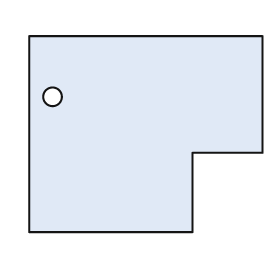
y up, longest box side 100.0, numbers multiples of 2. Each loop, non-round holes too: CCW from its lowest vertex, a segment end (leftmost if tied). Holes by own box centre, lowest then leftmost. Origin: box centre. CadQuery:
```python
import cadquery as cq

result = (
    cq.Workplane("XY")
    .moveTo(-50.0, -42.0)
    .lineTo(20.0, -42.0)
    .lineTo(20.0, -8.0)
    .lineTo(50.0, -8.0)
    .lineTo(50.0, 42.0)
    .lineTo(-50.0, 42.0)
    .close()
    .moveTo(-40.0, 16.0)
    .circle(4.0)
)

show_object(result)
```